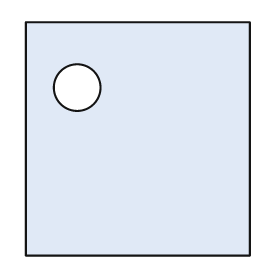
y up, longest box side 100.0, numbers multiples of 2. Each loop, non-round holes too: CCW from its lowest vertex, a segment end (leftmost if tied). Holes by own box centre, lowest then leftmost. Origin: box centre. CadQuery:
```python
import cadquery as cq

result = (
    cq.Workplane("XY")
    .moveTo(-48.0, -50.0)
    .lineTo(48.0, -50.0)
    .lineTo(48.0, 50.0)
    .lineTo(-48.0, 50.0)
    .close()
    .moveTo(-26.0, 22.0)
    .circle(10.0)
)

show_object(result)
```